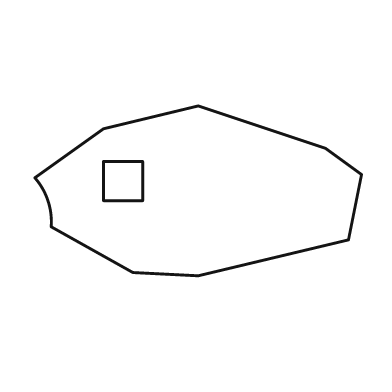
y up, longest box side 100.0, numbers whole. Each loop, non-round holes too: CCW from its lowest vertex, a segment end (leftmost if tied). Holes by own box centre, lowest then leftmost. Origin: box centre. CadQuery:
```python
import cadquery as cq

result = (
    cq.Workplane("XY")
    .moveTo(0.0, -26.0)
    .lineTo(46.0, -15.0)
    .lineTo(50.0, 5.0)
    .lineTo(39.0, 13.0)
    .lineTo(0.0, 26.0)
    .lineTo(-29.0, 19.0)
    .lineTo(-50.0, 4.0)
    .threePointArc((-46.0, -3.0), (-45.0, -11.0))
    .lineTo(-20.0, -25.0)
    .close()
    .moveTo(-29.0, -3.0)
    .lineTo(-17.0, -3.0)
    .lineTo(-17.0, 9.0)
    .lineTo(-29.0, 9.0)
    .close()
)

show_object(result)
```